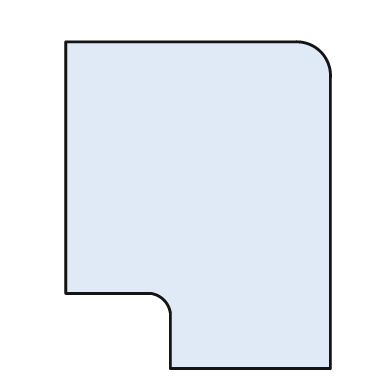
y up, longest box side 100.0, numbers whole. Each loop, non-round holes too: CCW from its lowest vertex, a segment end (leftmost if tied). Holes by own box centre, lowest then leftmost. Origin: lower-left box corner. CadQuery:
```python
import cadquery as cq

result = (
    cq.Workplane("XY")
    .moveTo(32.0, 0.0)
    .lineTo(81.0, 0.0)
    .lineTo(81.0, 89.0)
    .threePointArc((78.0, 97.0), (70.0, 100.0))
    .lineTo(0.0, 100.0)
    .lineTo(0.0, 23.0)
    .lineTo(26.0, 23.0)
    .threePointArc((30.0, 21.0), (32.0, 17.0))
    .close()
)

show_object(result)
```